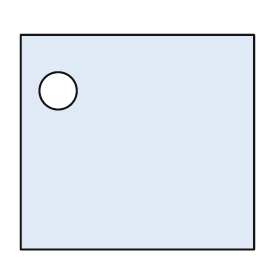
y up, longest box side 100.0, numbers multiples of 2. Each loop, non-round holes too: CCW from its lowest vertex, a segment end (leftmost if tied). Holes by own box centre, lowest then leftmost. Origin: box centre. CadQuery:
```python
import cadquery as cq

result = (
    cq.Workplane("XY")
    .moveTo(-50.0, -46.0)
    .lineTo(50.0, -46.0)
    .lineTo(50.0, 46.0)
    .lineTo(-50.0, 46.0)
    .close()
    .moveTo(-34.0, 22.0)
    .circle(8.0)
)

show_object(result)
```